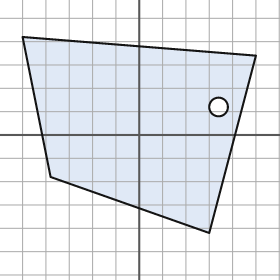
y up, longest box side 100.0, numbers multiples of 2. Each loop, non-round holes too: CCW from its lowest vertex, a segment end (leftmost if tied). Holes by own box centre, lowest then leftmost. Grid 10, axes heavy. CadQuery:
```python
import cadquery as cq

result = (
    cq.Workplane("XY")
    .moveTo(30.0, -42.0)
    .lineTo(50.0, 34.0)
    .lineTo(-50.0, 42.0)
    .lineTo(-38.0, -18.0)
    .close()
    .moveTo(34.0, 12.0)
    .circle(4.0)
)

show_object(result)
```